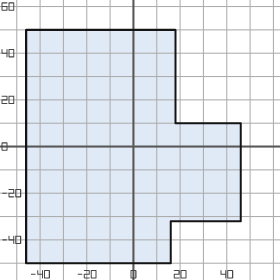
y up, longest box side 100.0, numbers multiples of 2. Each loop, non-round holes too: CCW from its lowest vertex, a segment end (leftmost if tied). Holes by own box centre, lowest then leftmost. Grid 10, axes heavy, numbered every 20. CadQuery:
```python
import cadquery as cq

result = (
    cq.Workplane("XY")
    .moveTo(-46.0, -50.0)
    .lineTo(16.0, -50.0)
    .lineTo(16.0, -32.0)
    .lineTo(46.0, -32.0)
    .lineTo(46.0, 10.0)
    .lineTo(18.0, 10.0)
    .lineTo(18.0, 50.0)
    .lineTo(-46.0, 50.0)
    .close()
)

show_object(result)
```